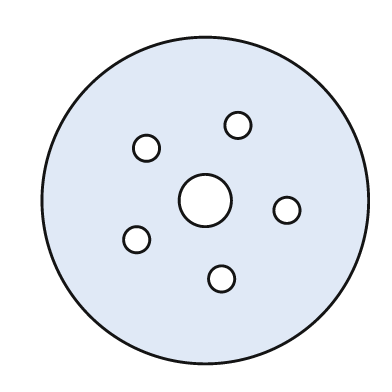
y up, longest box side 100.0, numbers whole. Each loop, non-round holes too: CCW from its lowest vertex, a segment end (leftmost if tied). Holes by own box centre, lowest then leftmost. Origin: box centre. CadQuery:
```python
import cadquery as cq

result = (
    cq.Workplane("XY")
    .moveTo(0.0, 0.0)
    .circle(50.0)
    .moveTo(5.0, -24.0)
    .circle(4.0)
    .moveTo(-21.0, -12.0)
    .circle(4.0)
    .moveTo(25.0, -3.0)
    .circle(4.0)
    .moveTo(0.0, 0.0)
    .circle(8.0)
    .moveTo(-18.0, 16.0)
    .circle(4.0)
    .moveTo(10.0, 23.0)
    .circle(4.0)
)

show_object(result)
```